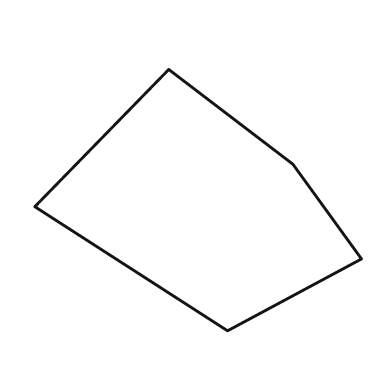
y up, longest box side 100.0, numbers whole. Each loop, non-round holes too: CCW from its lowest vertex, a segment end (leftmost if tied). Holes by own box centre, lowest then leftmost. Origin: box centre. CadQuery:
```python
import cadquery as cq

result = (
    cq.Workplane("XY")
    .moveTo(9.0, -40.0)
    .lineTo(50.0, -18.0)
    .lineTo(29.0, 11.0)
    .lineTo(-9.0, 40.0)
    .lineTo(-50.0, -2.0)
    .close()
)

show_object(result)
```